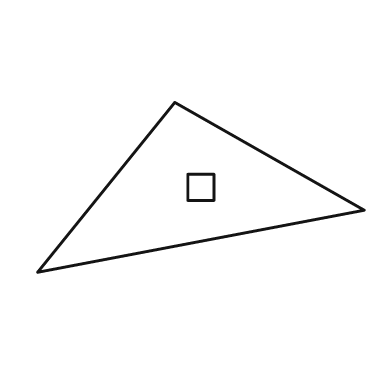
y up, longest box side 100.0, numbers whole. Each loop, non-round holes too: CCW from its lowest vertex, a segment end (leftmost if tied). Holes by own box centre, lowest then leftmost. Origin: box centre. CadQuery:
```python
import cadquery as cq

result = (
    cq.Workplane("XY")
    .moveTo(-50.0, -26.0)
    .lineTo(50.0, -7.0)
    .lineTo(-8.0, 26.0)
    .close()
    .moveTo(-4.0, -4.0)
    .lineTo(4.0, -4.0)
    .lineTo(4.0, 4.0)
    .lineTo(-4.0, 4.0)
    .close()
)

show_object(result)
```